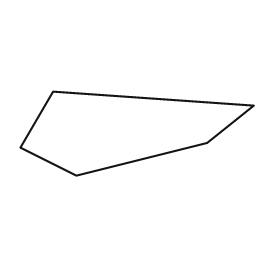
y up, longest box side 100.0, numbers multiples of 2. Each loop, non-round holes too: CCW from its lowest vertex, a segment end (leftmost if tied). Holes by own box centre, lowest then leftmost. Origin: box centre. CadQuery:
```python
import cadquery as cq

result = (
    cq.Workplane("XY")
    .moveTo(-26.0, -18.0)
    .lineTo(30.0, -4.0)
    .lineTo(50.0, 12.0)
    .lineTo(-36.0, 18.0)
    .lineTo(-50.0, -6.0)
    .close()
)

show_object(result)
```